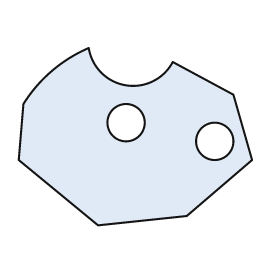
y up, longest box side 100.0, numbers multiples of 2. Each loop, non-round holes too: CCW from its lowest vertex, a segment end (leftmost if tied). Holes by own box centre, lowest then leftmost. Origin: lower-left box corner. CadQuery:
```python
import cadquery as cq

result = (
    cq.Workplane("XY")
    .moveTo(34.0, 0.0)
    .lineTo(72.0, 4.0)
    .lineTo(100.0, 28.0)
    .lineTo(92.0, 56.0)
    .lineTo(66.0, 70.0)
    .threePointArc((46.0, 60.0), (30.0, 76.0))
    .threePointArc((14.0, 66.0), (2.0, 52.0))
    .lineTo(0.0, 28.0)
    .close()
    .moveTo(84.0, 36.0)
    .circle(8.0)
    .moveTo(46.0, 44.0)
    .circle(8.0)
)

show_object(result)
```